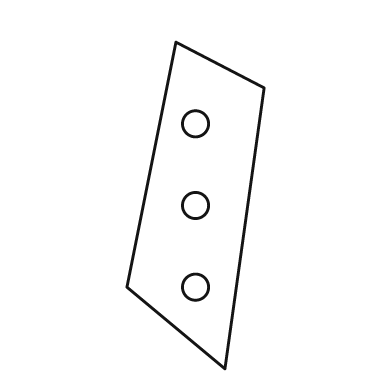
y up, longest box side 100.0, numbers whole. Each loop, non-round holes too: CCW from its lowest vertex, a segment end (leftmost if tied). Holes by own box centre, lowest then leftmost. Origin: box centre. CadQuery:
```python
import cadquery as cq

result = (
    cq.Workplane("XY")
    .moveTo(9.0, -50.0)
    .lineTo(21.0, 36.0)
    .lineTo(-6.0, 50.0)
    .lineTo(-21.0, -25.0)
    .close()
    .moveTo(0.0, -25.0)
    .circle(4.0)
    .moveTo(0.0, 0.0)
    .circle(4.0)
    .moveTo(0.0, 25.0)
    .circle(4.0)
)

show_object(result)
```